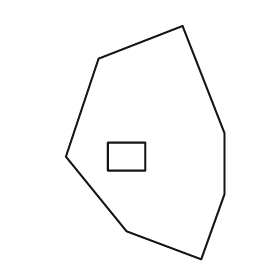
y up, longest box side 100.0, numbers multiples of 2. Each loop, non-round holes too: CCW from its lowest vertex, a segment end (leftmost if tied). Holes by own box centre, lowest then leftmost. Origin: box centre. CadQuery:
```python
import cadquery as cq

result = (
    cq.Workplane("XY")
    .moveTo(24.0, -50.0)
    .lineTo(34.0, -22.0)
    .lineTo(34.0, 4.0)
    .lineTo(16.0, 50.0)
    .lineTo(-20.0, 36.0)
    .lineTo(-34.0, -6.0)
    .lineTo(-8.0, -38.0)
    .close()
    .moveTo(-16.0, -12.0)
    .lineTo(0.0, -12.0)
    .lineTo(0.0, 0.0)
    .lineTo(-16.0, 0.0)
    .close()
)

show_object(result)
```